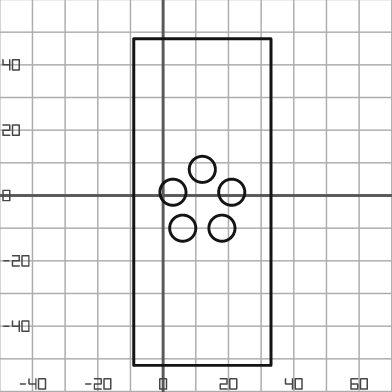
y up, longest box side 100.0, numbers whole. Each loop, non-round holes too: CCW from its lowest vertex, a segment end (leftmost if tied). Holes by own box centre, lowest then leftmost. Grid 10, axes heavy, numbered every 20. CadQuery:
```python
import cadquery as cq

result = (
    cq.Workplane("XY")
    .moveTo(-9.0, -52.0)
    .lineTo(33.0, -52.0)
    .lineTo(33.0, 48.0)
    .lineTo(-9.0, 48.0)
    .close()
    .moveTo(6.0, -10.0)
    .circle(4.0)
    .moveTo(18.0, -10.0)
    .circle(4.0)
    .moveTo(3.0, 1.0)
    .circle(4.0)
    .moveTo(21.0, 1.0)
    .circle(4.0)
    .moveTo(12.0, 8.0)
    .circle(4.0)
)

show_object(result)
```